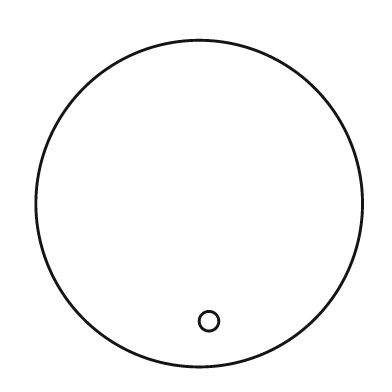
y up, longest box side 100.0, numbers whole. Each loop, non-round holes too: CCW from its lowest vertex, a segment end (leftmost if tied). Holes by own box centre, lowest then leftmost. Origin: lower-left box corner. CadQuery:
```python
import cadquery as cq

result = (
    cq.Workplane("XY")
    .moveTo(50.0, 50.0)
    .circle(50.0)
    .moveTo(53.0, 14.0)
    .circle(3.0)
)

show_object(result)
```